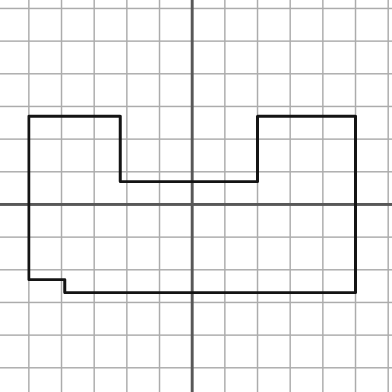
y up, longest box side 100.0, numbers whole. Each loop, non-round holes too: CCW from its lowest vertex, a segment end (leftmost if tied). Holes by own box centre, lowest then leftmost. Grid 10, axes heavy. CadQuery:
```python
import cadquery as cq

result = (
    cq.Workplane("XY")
    .moveTo(-39.0, -27.0)
    .lineTo(50.0, -27.0)
    .lineTo(50.0, 27.0)
    .lineTo(20.0, 27.0)
    .lineTo(20.0, 7.0)
    .lineTo(-22.0, 7.0)
    .lineTo(-22.0, 27.0)
    .lineTo(-50.0, 27.0)
    .lineTo(-50.0, -23.0)
    .lineTo(-39.0, -23.0)
    .close()
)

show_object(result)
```